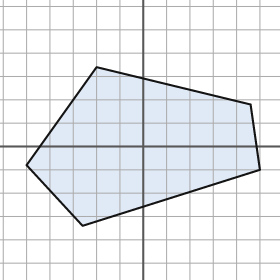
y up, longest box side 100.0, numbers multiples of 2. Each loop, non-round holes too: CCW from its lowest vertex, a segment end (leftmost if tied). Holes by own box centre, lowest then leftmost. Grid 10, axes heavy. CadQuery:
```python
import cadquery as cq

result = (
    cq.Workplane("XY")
    .moveTo(-26.0, -34.0)
    .lineTo(50.0, -10.0)
    .lineTo(46.0, 18.0)
    .lineTo(-20.0, 34.0)
    .lineTo(-50.0, -8.0)
    .close()
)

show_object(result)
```